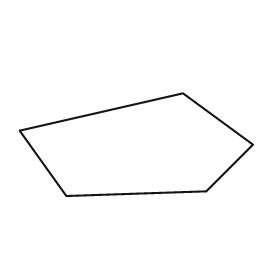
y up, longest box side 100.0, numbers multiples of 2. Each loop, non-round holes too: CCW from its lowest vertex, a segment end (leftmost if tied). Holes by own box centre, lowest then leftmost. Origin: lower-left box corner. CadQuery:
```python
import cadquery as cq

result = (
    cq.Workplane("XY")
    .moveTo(20.0, 0.0)
    .lineTo(80.0, 2.0)
    .lineTo(100.0, 22.0)
    .lineTo(70.0, 44.0)
    .lineTo(0.0, 28.0)
    .close()
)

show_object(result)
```